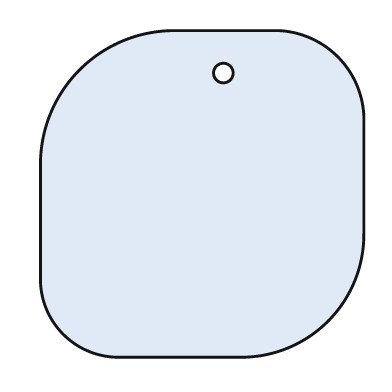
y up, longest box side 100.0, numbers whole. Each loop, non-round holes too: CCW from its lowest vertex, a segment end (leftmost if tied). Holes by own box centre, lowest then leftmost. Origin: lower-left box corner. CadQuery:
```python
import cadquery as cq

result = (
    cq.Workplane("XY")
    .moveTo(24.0, 0.0)
    .lineTo(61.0, 0.0)
    .threePointArc((88.0, 11.0), (99.0, 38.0))
    .lineTo(99.0, 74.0)
    .threePointArc((91.0, 92.0), (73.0, 100.0))
    .lineTo(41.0, 100.0)
    .threePointArc((12.0, 88.0), (0.0, 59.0))
    .lineTo(0.0, 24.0)
    .threePointArc((7.0, 7.0), (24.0, 0.0))
    .close()
    .moveTo(56.0, 87.0)
    .circle(3.0)
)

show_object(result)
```